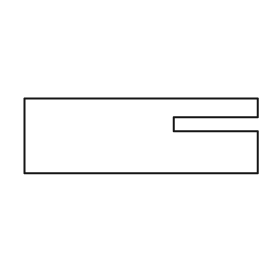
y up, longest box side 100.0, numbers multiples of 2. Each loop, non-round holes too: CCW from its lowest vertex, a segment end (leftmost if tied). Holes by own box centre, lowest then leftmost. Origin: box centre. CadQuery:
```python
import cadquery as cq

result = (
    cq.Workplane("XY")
    .moveTo(-50.0, -16.0)
    .lineTo(50.0, -16.0)
    .lineTo(50.0, 2.0)
    .lineTo(14.0, 2.0)
    .lineTo(14.0, 8.0)
    .lineTo(50.0, 8.0)
    .lineTo(50.0, 16.0)
    .lineTo(-50.0, 16.0)
    .close()
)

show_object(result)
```